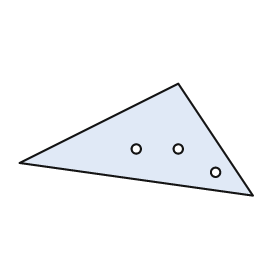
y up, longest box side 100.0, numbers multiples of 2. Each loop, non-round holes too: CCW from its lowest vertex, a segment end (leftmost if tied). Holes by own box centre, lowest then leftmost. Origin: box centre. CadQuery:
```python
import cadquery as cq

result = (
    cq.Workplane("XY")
    .moveTo(50.0, -24.0)
    .lineTo(18.0, 24.0)
    .lineTo(-50.0, -10.0)
    .close()
    .moveTo(34.0, -14.0)
    .circle(2.0)
    .moveTo(0.0, -4.0)
    .circle(2.0)
    .moveTo(18.0, -4.0)
    .circle(2.0)
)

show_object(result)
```